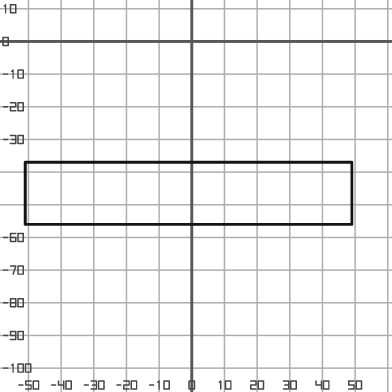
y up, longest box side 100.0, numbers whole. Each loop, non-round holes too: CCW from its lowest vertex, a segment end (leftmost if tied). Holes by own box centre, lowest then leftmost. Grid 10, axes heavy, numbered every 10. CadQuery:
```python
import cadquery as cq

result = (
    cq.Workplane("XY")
    .moveTo(-51.0, -56.0)
    .lineTo(49.0, -56.0)
    .lineTo(49.0, -37.0)
    .lineTo(-51.0, -37.0)
    .close()
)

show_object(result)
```